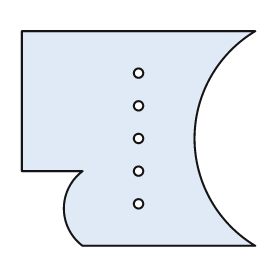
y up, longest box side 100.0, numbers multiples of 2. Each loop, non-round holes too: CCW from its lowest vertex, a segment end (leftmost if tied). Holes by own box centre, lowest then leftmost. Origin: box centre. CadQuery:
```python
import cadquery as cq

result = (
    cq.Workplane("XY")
    .moveTo(-24.0, -46.0)
    .lineTo(50.0, -46.0)
    .threePointArc((24.0, 0.0), (50.0, 46.0))
    .lineTo(-50.0, 46.0)
    .lineTo(-50.0, -14.0)
    .lineTo(-24.0, -14.0)
    .threePointArc((-32.0, -30.0), (-24.0, -46.0))
    .close()
    .moveTo(0.0, -28.0)
    .circle(2.0)
    .moveTo(0.0, -14.0)
    .circle(2.0)
    .moveTo(0.0, 0.0)
    .circle(2.0)
    .moveTo(0.0, 14.0)
    .circle(2.0)
    .moveTo(0.0, 28.0)
    .circle(2.0)
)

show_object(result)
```